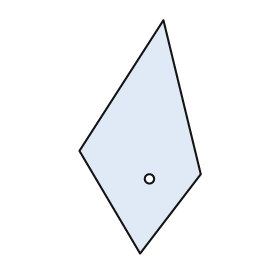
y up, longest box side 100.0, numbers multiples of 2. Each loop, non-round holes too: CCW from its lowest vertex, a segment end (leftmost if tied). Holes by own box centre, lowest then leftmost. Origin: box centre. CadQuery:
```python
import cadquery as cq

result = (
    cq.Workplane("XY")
    .moveTo(0.0, -50.0)
    .lineTo(26.0, -16.0)
    .lineTo(10.0, 50.0)
    .lineTo(-26.0, -6.0)
    .close()
    .moveTo(4.0, -18.0)
    .circle(2.0)
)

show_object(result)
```